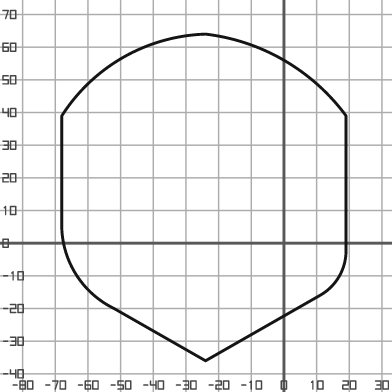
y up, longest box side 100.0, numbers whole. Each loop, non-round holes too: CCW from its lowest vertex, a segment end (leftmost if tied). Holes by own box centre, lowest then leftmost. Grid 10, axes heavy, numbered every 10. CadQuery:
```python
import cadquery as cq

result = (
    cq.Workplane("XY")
    .moveTo(-24.0, -36.0)
    .lineTo(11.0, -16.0)
    .threePointArc((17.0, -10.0), (19.0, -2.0))
    .lineTo(19.0, 39.0)
    .threePointArc((0.0, 56.0), (-24.0, 64.0))
    .threePointArc((-49.0, 57.0), (-68.0, 39.0))
    .lineTo(-68.0, 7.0)
    .threePointArc((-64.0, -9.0), (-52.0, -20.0))
    .close()
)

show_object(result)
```